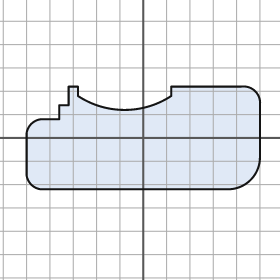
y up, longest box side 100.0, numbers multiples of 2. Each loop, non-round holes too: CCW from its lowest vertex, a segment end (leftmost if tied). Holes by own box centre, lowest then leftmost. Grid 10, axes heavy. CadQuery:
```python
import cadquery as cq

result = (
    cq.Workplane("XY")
    .moveTo(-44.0, -22.0)
    .lineTo(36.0, -22.0)
    .threePointArc((46.0, -18.0), (50.0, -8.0))
    .lineTo(50.0, 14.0)
    .threePointArc((48.0, 20.0), (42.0, 22.0))
    .lineTo(12.0, 22.0)
    .lineTo(12.0, 18.0)
    .threePointArc((-8.0, 12.0), (-28.0, 18.0))
    .lineTo(-28.0, 22.0)
    .lineTo(-32.0, 22.0)
    .lineTo(-32.0, 14.0)
    .lineTo(-36.0, 14.0)
    .lineTo(-36.0, 8.0)
    .lineTo(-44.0, 8.0)
    .threePointArc((-48.0, 6.0), (-50.0, 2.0))
    .lineTo(-50.0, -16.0)
    .threePointArc((-48.0, -20.0), (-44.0, -22.0))
    .close()
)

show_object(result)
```